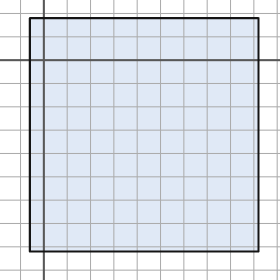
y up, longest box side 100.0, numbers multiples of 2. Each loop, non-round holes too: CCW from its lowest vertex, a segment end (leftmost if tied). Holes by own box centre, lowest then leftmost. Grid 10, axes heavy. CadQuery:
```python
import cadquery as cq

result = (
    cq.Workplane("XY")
    .moveTo(-6.0, -82.0)
    .lineTo(92.0, -82.0)
    .lineTo(92.0, 18.0)
    .lineTo(-6.0, 18.0)
    .close()
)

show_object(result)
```